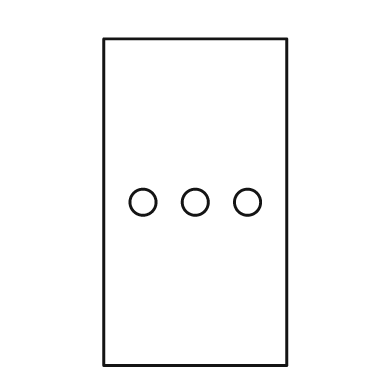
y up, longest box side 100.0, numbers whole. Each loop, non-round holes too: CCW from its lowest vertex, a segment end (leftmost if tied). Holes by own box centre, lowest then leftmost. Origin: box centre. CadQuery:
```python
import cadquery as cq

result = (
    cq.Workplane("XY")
    .moveTo(-28.0, -50.0)
    .lineTo(28.0, -50.0)
    .lineTo(28.0, 50.0)
    .lineTo(-28.0, 50.0)
    .close()
    .moveTo(-16.0, 0.0)
    .circle(4.0)
    .moveTo(0.0, 0.0)
    .circle(4.0)
    .moveTo(16.0, 0.0)
    .circle(4.0)
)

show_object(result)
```